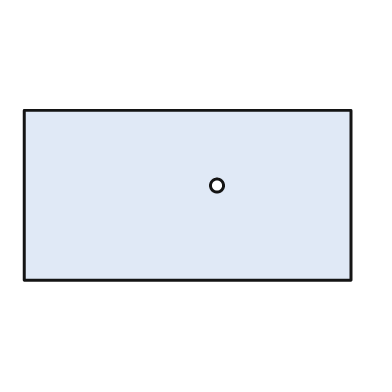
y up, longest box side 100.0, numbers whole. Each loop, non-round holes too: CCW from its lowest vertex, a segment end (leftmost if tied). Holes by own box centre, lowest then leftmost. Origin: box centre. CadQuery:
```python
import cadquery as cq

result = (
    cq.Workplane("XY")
    .moveTo(-50.0, -26.0)
    .lineTo(50.0, -26.0)
    .lineTo(50.0, 26.0)
    .lineTo(-50.0, 26.0)
    .close()
    .moveTo(9.0, 3.0)
    .circle(2.0)
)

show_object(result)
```